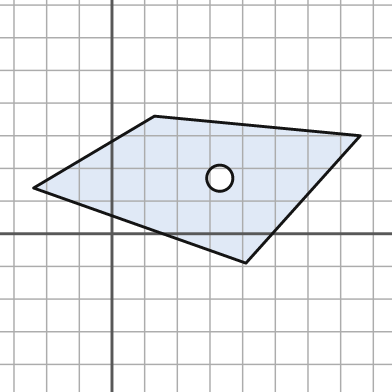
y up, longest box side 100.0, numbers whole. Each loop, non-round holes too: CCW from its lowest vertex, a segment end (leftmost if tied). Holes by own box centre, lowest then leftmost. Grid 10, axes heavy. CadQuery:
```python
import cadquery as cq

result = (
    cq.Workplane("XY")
    .moveTo(41.0, -9.0)
    .lineTo(76.0, 30.0)
    .lineTo(13.0, 36.0)
    .lineTo(-24.0, 14.0)
    .close()
    .moveTo(33.0, 17.0)
    .circle(4.0)
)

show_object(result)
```